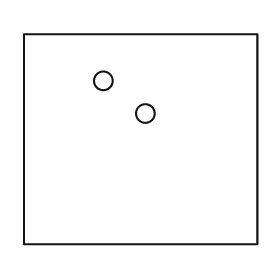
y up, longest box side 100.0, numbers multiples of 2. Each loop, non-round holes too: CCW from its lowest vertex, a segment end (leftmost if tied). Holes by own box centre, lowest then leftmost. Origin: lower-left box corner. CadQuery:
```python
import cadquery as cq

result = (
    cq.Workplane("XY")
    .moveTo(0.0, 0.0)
    .lineTo(100.0, 0.0)
    .lineTo(100.0, 90.0)
    .lineTo(0.0, 90.0)
    .close()
    .moveTo(52.0, 56.0)
    .circle(4.0)
    .moveTo(34.0, 70.0)
    .circle(4.0)
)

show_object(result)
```